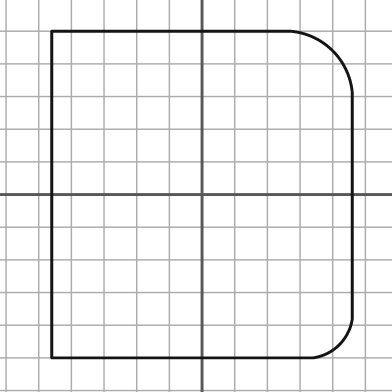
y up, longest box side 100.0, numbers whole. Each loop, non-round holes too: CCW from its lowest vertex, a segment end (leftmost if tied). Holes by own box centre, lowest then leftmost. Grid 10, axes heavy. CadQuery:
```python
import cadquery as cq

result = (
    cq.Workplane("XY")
    .moveTo(-46.0, -50.0)
    .lineTo(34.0, -50.0)
    .threePointArc((42.0, -46.0), (46.0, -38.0))
    .lineTo(46.0, 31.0)
    .threePointArc((40.0, 44.0), (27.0, 50.0))
    .lineTo(-46.0, 50.0)
    .close()
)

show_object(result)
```